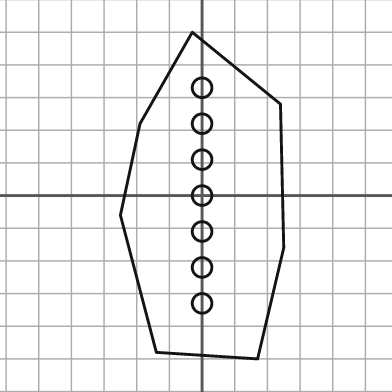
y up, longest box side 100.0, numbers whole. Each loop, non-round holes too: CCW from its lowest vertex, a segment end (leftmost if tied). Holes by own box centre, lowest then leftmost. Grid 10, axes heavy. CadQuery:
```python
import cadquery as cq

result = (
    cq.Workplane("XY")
    .moveTo(17.0, -50.0)
    .lineTo(25.0, -16.0)
    .lineTo(24.0, 28.0)
    .lineTo(-3.0, 50.0)
    .lineTo(-19.0, 22.0)
    .lineTo(-25.0, -6.0)
    .lineTo(-14.0, -48.0)
    .close()
    .moveTo(0.0, -33.0)
    .circle(3.0)
    .moveTo(0.0, -22.0)
    .circle(3.0)
    .moveTo(0.0, -11.0)
    .circle(3.0)
    .moveTo(0.0, 0.0)
    .circle(3.0)
    .moveTo(0.0, 11.0)
    .circle(3.0)
    .moveTo(0.0, 22.0)
    .circle(3.0)
    .moveTo(0.0, 33.0)
    .circle(3.0)
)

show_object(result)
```